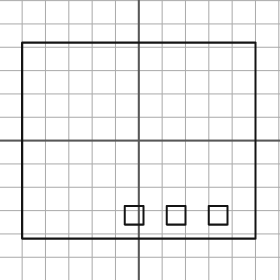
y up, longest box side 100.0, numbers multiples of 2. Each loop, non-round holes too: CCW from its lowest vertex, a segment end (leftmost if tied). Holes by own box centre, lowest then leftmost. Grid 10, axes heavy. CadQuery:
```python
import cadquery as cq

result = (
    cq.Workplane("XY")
    .moveTo(-50.0, -42.0)
    .lineTo(50.0, -42.0)
    .lineTo(50.0, 42.0)
    .lineTo(-50.0, 42.0)
    .close()
    .moveTo(-6.0, -36.0)
    .lineTo(2.0, -36.0)
    .lineTo(2.0, -28.0)
    .lineTo(-6.0, -28.0)
    .close()
    .moveTo(12.0, -36.0)
    .lineTo(20.0, -36.0)
    .lineTo(20.0, -28.0)
    .lineTo(12.0, -28.0)
    .close()
    .moveTo(30.0, -36.0)
    .lineTo(38.0, -36.0)
    .lineTo(38.0, -28.0)
    .lineTo(30.0, -28.0)
    .close()
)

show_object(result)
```